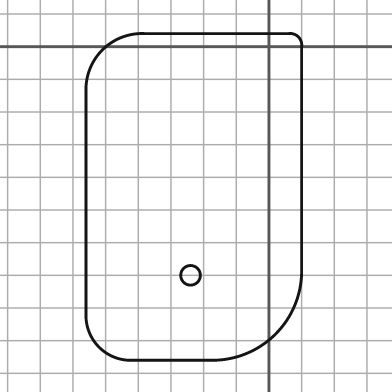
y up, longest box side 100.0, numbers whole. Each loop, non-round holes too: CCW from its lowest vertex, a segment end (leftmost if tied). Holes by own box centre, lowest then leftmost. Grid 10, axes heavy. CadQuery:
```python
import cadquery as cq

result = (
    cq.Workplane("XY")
    .moveTo(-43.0, -96.0)
    .lineTo(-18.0, -96.0)
    .threePointArc((2.0, -88.0), (10.0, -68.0))
    .lineTo(10.0, 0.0)
    .threePointArc((9.0, 3.0), (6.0, 4.0))
    .lineTo(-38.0, 4.0)
    .threePointArc((-51.0, -1.0), (-56.0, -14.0))
    .lineTo(-56.0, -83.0)
    .threePointArc((-52.0, -92.0), (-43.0, -96.0))
    .close()
    .moveTo(-24.0, -70.0)
    .circle(3.0)
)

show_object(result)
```